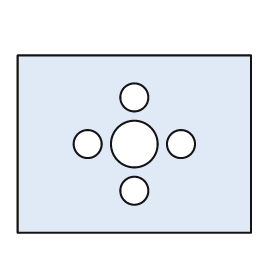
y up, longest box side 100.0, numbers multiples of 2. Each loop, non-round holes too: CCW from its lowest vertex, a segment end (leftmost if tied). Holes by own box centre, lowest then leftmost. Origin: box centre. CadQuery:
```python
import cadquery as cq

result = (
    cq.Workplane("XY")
    .moveTo(-50.0, -38.0)
    .lineTo(50.0, -38.0)
    .lineTo(50.0, 38.0)
    .lineTo(-50.0, 38.0)
    .close()
    .moveTo(0.0, -20.0)
    .circle(6.0)
    .moveTo(-20.0, 0.0)
    .circle(6.0)
    .moveTo(0.0, 0.0)
    .circle(10.0)
    .moveTo(20.0, 0.0)
    .circle(6.0)
    .moveTo(0.0, 20.0)
    .circle(6.0)
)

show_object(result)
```